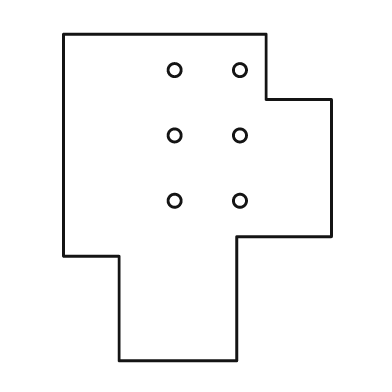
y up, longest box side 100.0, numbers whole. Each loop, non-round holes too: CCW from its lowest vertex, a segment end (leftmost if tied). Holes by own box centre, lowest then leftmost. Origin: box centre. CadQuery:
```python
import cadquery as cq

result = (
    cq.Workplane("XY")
    .moveTo(-24.0, -50.0)
    .lineTo(12.0, -50.0)
    .lineTo(12.0, -12.0)
    .lineTo(41.0, -12.0)
    .lineTo(41.0, 30.0)
    .lineTo(21.0, 30.0)
    .lineTo(21.0, 50.0)
    .lineTo(-41.0, 50.0)
    .lineTo(-41.0, -18.0)
    .lineTo(-24.0, -18.0)
    .close()
    .moveTo(-7.0, -1.0)
    .circle(2.0)
    .moveTo(13.0, -1.0)
    .circle(2.0)
    .moveTo(-7.0, 19.0)
    .circle(2.0)
    .moveTo(13.0, 19.0)
    .circle(2.0)
    .moveTo(-7.0, 39.0)
    .circle(2.0)
    .moveTo(13.0, 39.0)
    .circle(2.0)
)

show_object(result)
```